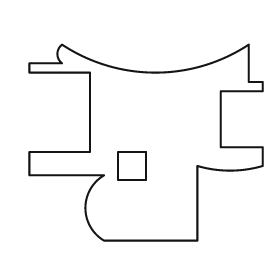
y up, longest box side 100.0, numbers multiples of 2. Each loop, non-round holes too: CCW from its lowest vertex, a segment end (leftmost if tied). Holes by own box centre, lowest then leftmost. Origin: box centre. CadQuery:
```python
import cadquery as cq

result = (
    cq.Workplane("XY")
    .moveTo(-18.0, -42.0)
    .lineTo(22.0, -42.0)
    .lineTo(22.0, -10.0)
    .threePointArc((36.0, -12.0), (50.0, -10.0))
    .lineTo(50.0, -2.0)
    .lineTo(32.0, -2.0)
    .lineTo(32.0, 22.0)
    .lineTo(50.0, 22.0)
    .lineTo(50.0, 26.0)
    .lineTo(44.0, 26.0)
    .lineTo(44.0, 42.0)
    .threePointArc((4.0, 30.0), (-36.0, 42.0))
    .threePointArc((-38.0, 38.0), (-36.0, 34.0))
    .lineTo(-50.0, 34.0)
    .lineTo(-50.0, 30.0)
    .lineTo(-24.0, 30.0)
    .lineTo(-24.0, -4.0)
    .lineTo(-50.0, -4.0)
    .lineTo(-50.0, -14.0)
    .lineTo(-18.0, -14.0)
    .threePointArc((-26.0, -28.0), (-18.0, -42.0))
    .close()
    .moveTo(-12.0, -16.0)
    .lineTo(0.0, -16.0)
    .lineTo(0.0, -4.0)
    .lineTo(-12.0, -4.0)
    .close()
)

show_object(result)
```